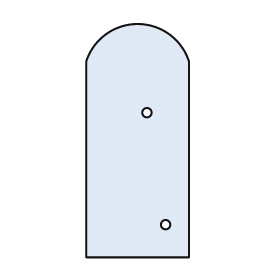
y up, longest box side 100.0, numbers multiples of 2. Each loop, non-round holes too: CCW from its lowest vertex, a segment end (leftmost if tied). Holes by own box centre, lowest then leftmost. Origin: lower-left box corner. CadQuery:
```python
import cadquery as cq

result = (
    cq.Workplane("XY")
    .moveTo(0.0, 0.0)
    .lineTo(44.0, 0.0)
    .lineTo(44.0, 84.0)
    .threePointArc((22.0, 100.0), (0.0, 84.0))
    .close()
    .moveTo(34.0, 14.0)
    .circle(2.0)
    .moveTo(26.0, 62.0)
    .circle(2.0)
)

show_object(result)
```